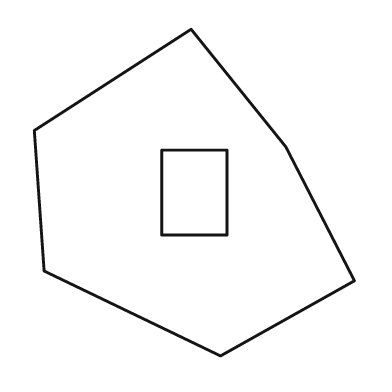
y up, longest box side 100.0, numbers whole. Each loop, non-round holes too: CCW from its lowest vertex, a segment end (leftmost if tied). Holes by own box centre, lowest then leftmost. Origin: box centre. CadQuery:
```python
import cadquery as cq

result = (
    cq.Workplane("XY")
    .moveTo(8.0, -50.0)
    .lineTo(49.0, -27.0)
    .lineTo(28.0, 14.0)
    .lineTo(-1.0, 50.0)
    .lineTo(-49.0, 19.0)
    .lineTo(-46.0, -24.0)
    .close()
    .moveTo(-10.0, -13.0)
    .lineTo(10.0, -13.0)
    .lineTo(10.0, 13.0)
    .lineTo(-10.0, 13.0)
    .close()
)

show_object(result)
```